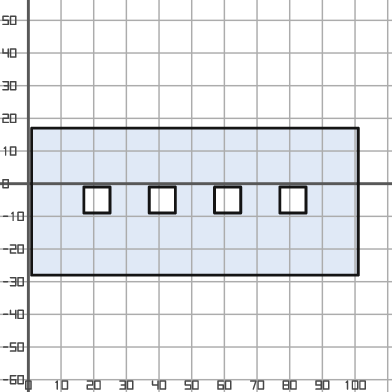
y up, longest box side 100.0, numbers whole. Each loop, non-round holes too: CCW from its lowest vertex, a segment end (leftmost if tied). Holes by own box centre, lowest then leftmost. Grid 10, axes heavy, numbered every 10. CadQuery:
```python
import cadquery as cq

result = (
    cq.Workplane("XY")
    .moveTo(1.0, -28.0)
    .lineTo(101.0, -28.0)
    .lineTo(101.0, 17.0)
    .lineTo(1.0, 17.0)
    .close()
    .moveTo(17.0, -9.0)
    .lineTo(25.0, -9.0)
    .lineTo(25.0, -1.0)
    .lineTo(17.0, -1.0)
    .close()
    .moveTo(37.0, -9.0)
    .lineTo(45.0, -9.0)
    .lineTo(45.0, -1.0)
    .lineTo(37.0, -1.0)
    .close()
    .moveTo(57.0, -9.0)
    .lineTo(65.0, -9.0)
    .lineTo(65.0, -1.0)
    .lineTo(57.0, -1.0)
    .close()
    .moveTo(77.0, -9.0)
    .lineTo(85.0, -9.0)
    .lineTo(85.0, -1.0)
    .lineTo(77.0, -1.0)
    .close()
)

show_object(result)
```